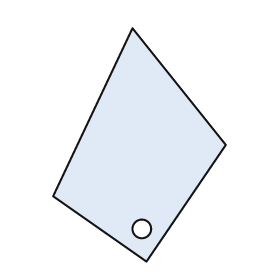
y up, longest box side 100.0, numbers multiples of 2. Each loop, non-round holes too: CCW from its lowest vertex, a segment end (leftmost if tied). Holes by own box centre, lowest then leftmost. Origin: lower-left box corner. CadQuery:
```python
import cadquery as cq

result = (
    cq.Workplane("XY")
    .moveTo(40.0, 0.0)
    .lineTo(74.0, 50.0)
    .lineTo(34.0, 100.0)
    .lineTo(0.0, 28.0)
    .close()
    .moveTo(38.0, 14.0)
    .circle(4.0)
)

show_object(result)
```